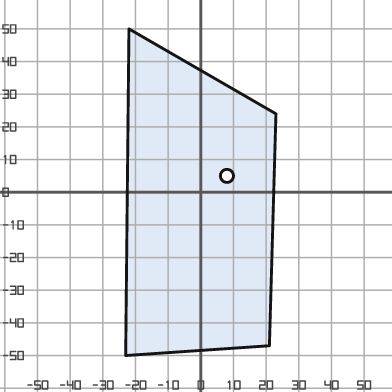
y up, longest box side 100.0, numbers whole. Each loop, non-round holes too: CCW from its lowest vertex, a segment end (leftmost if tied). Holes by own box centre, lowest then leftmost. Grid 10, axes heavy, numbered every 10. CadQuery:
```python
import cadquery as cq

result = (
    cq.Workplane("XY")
    .moveTo(-23.0, -50.0)
    .lineTo(21.0, -47.0)
    .lineTo(23.0, 24.0)
    .lineTo(-22.0, 50.0)
    .close()
    .moveTo(8.0, 5.0)
    .circle(2.0)
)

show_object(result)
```